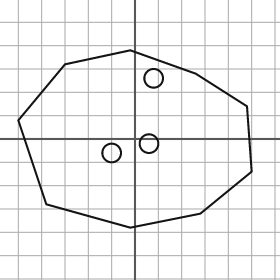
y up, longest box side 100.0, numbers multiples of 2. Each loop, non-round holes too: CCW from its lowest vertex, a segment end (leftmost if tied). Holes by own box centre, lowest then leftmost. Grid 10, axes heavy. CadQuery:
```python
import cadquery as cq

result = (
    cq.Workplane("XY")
    .moveTo(-2.0, -38.0)
    .lineTo(28.0, -32.0)
    .lineTo(50.0, -14.0)
    .lineTo(48.0, 14.0)
    .lineTo(26.0, 28.0)
    .lineTo(-2.0, 38.0)
    .lineTo(-30.0, 32.0)
    .lineTo(-50.0, 8.0)
    .lineTo(-38.0, -28.0)
    .close()
    .moveTo(-10.0, -6.0)
    .circle(4.0)
    .moveTo(6.0, -2.0)
    .circle(4.0)
    .moveTo(8.0, 26.0)
    .circle(4.0)
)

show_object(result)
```